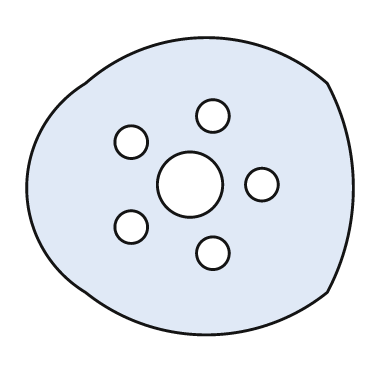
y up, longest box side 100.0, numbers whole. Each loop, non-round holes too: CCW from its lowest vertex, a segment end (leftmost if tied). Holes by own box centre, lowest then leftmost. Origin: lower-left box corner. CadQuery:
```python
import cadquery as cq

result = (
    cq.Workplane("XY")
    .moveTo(18.0, 13.0)
    .threePointArc((55.0, 0.0), (92.0, 13.0))
    .threePointArc((100.0, 45.0), (92.0, 77.0))
    .threePointArc((55.0, 91.0), (18.0, 77.0))
    .threePointArc((0.0, 45.0), (18.0, 13.0))
    .close()
    .moveTo(57.0, 25.0)
    .circle(5.0)
    .moveTo(32.0, 33.0)
    .circle(5.0)
    .moveTo(50.0, 46.0)
    .circle(10.0)
    .moveTo(72.0, 46.0)
    .circle(5.0)
    .moveTo(32.0, 59.0)
    .circle(5.0)
    .moveTo(57.0, 67.0)
    .circle(5.0)
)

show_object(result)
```